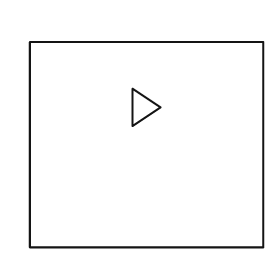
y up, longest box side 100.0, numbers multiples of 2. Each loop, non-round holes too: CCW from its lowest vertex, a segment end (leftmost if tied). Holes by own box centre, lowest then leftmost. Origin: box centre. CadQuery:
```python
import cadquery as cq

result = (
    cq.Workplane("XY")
    .moveTo(-50.0, -44.0)
    .lineTo(50.0, -44.0)
    .lineTo(50.0, 44.0)
    .lineTo(-50.0, 44.0)
    .close()
    .moveTo(-6.0, 8.0)
    .lineTo(6.0, 16.0)
    .lineTo(-6.0, 24.0)
    .close()
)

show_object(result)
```